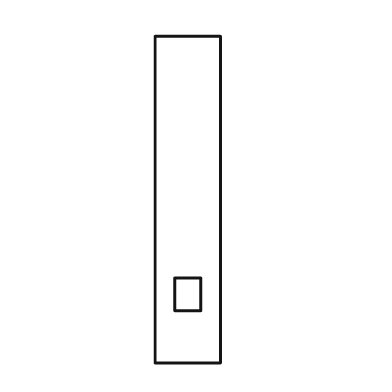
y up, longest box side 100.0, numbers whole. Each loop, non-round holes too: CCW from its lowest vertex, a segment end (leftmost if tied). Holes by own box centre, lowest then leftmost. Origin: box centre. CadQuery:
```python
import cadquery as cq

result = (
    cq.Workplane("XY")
    .moveTo(-10.0, -50.0)
    .lineTo(10.0, -50.0)
    .lineTo(10.0, 50.0)
    .lineTo(-10.0, 50.0)
    .close()
    .moveTo(-4.0, -34.0)
    .lineTo(4.0, -34.0)
    .lineTo(4.0, -24.0)
    .lineTo(-4.0, -24.0)
    .close()
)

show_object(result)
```